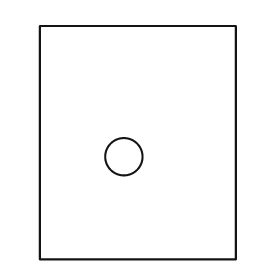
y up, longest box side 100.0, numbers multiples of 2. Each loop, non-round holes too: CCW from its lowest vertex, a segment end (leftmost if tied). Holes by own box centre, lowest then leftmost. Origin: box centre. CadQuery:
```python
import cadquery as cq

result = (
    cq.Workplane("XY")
    .moveTo(-42.0, -50.0)
    .lineTo(42.0, -50.0)
    .lineTo(42.0, 50.0)
    .lineTo(-42.0, 50.0)
    .close()
    .moveTo(-6.0, -6.0)
    .circle(8.0)
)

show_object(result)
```